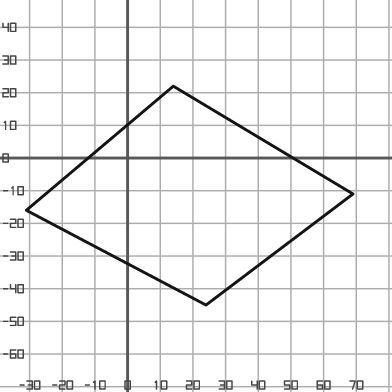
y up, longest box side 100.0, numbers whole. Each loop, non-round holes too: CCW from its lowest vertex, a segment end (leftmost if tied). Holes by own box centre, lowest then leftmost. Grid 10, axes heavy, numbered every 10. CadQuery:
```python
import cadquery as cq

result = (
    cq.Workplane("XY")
    .moveTo(24.0, -45.0)
    .lineTo(69.0, -11.0)
    .lineTo(14.0, 22.0)
    .lineTo(-31.0, -16.0)
    .close()
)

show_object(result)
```